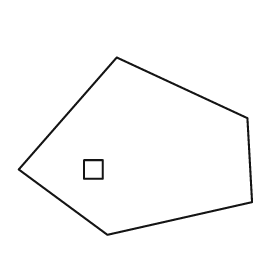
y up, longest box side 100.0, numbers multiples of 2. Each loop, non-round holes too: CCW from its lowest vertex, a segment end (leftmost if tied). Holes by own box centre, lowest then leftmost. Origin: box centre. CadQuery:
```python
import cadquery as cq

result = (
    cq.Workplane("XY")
    .moveTo(-12.0, -38.0)
    .lineTo(50.0, -24.0)
    .lineTo(48.0, 12.0)
    .lineTo(-8.0, 38.0)
    .lineTo(-50.0, -10.0)
    .close()
    .moveTo(-22.0, -14.0)
    .lineTo(-14.0, -14.0)
    .lineTo(-14.0, -6.0)
    .lineTo(-22.0, -6.0)
    .close()
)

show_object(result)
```